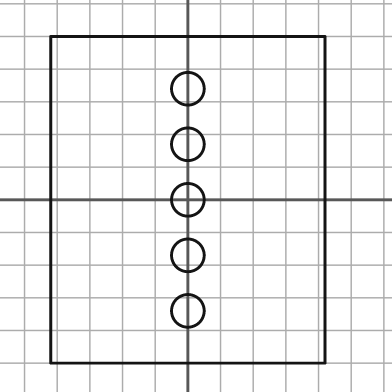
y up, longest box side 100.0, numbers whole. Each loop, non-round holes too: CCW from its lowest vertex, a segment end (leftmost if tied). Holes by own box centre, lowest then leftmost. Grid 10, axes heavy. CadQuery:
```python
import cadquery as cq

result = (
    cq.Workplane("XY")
    .moveTo(-42.0, -50.0)
    .lineTo(42.0, -50.0)
    .lineTo(42.0, 50.0)
    .lineTo(-42.0, 50.0)
    .close()
    .moveTo(0.0, -34.0)
    .circle(5.0)
    .moveTo(0.0, -17.0)
    .circle(5.0)
    .moveTo(0.0, 0.0)
    .circle(5.0)
    .moveTo(0.0, 17.0)
    .circle(5.0)
    .moveTo(0.0, 34.0)
    .circle(5.0)
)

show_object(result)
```